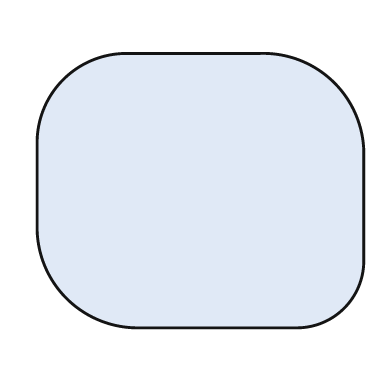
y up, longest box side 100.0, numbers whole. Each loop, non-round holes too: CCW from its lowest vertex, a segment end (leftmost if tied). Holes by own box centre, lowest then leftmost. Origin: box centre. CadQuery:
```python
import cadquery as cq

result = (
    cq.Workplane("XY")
    .moveTo(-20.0, -42.0)
    .lineTo(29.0, -42.0)
    .threePointArc((44.0, -36.0), (50.0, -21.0))
    .lineTo(50.0, 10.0)
    .threePointArc((41.0, 33.0), (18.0, 42.0))
    .lineTo(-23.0, 42.0)
    .threePointArc((-42.0, 34.0), (-50.0, 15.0))
    .lineTo(-50.0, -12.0)
    .threePointArc((-41.0, -33.0), (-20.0, -42.0))
    .close()
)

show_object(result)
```